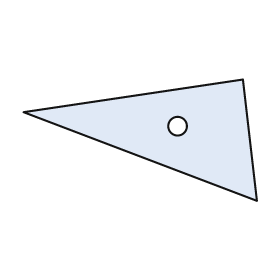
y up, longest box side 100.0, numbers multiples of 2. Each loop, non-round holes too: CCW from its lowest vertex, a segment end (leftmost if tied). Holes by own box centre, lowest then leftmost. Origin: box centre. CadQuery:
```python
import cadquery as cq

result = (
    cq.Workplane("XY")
    .moveTo(50.0, -26.0)
    .lineTo(44.0, 26.0)
    .lineTo(-50.0, 12.0)
    .close()
    .moveTo(16.0, 6.0)
    .circle(4.0)
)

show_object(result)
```